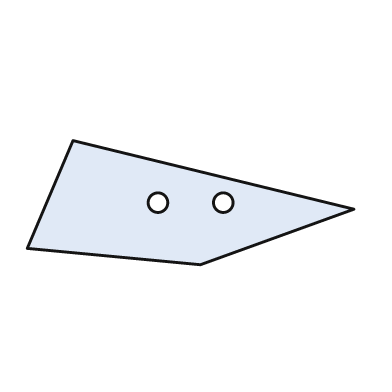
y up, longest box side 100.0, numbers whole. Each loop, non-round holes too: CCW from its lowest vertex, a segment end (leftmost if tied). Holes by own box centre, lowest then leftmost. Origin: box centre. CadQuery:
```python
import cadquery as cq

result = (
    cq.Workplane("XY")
    .moveTo(3.0, -19.0)
    .lineTo(50.0, -2.0)
    .lineTo(-36.0, 19.0)
    .lineTo(-50.0, -14.0)
    .close()
    .moveTo(-10.0, 0.0)
    .circle(3.0)
    .moveTo(10.0, 0.0)
    .circle(3.0)
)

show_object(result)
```